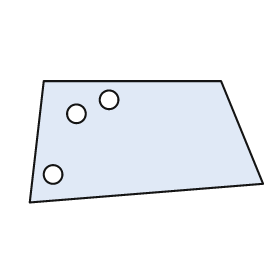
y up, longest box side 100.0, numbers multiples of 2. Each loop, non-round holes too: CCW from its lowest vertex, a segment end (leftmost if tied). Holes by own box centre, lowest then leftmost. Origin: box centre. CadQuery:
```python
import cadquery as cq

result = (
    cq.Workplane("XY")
    .moveTo(-50.0, -26.0)
    .lineTo(50.0, -18.0)
    .lineTo(32.0, 26.0)
    .lineTo(-44.0, 26.0)
    .close()
    .moveTo(-40.0, -14.0)
    .circle(4.0)
    .moveTo(-30.0, 12.0)
    .circle(4.0)
    .moveTo(-16.0, 18.0)
    .circle(4.0)
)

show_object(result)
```